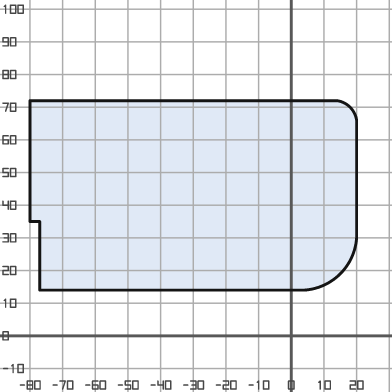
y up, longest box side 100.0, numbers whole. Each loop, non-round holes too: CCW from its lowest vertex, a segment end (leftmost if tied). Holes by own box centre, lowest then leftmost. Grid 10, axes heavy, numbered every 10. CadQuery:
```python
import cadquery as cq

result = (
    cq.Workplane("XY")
    .moveTo(-77.0, 14.0)
    .lineTo(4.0, 14.0)
    .threePointArc((15.0, 19.0), (20.0, 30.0))
    .lineTo(20.0, 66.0)
    .threePointArc((18.0, 70.0), (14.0, 72.0))
    .lineTo(-80.0, 72.0)
    .lineTo(-80.0, 35.0)
    .lineTo(-77.0, 35.0)
    .close()
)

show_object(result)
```